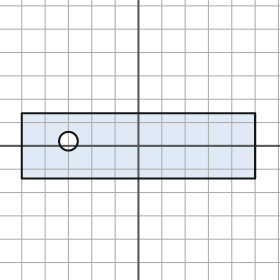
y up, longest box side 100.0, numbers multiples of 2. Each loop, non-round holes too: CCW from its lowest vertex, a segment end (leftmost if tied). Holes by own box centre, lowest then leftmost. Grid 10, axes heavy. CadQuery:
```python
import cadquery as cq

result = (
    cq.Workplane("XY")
    .moveTo(-50.0, -14.0)
    .lineTo(50.0, -14.0)
    .lineTo(50.0, 14.0)
    .lineTo(-50.0, 14.0)
    .close()
    .moveTo(-30.0, 2.0)
    .circle(4.0)
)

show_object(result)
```